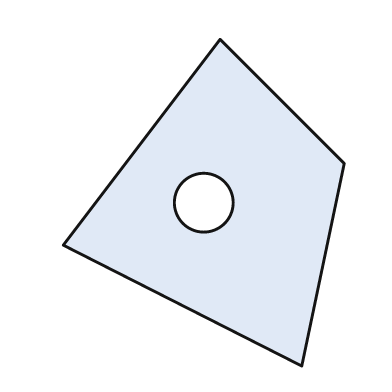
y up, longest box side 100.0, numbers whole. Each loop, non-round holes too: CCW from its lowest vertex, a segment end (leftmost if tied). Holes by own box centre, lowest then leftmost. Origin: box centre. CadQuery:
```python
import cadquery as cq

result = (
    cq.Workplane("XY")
    .moveTo(30.0, -50.0)
    .lineTo(43.0, 12.0)
    .lineTo(5.0, 50.0)
    .lineTo(-43.0, -13.0)
    .close()
    .moveTo(0.0, 0.0)
    .circle(9.0)
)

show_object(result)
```